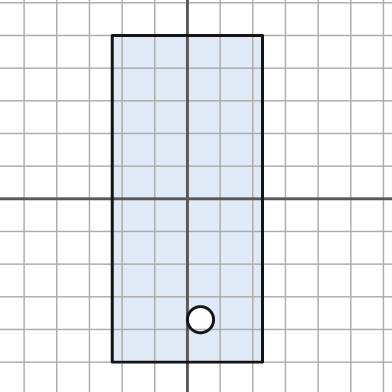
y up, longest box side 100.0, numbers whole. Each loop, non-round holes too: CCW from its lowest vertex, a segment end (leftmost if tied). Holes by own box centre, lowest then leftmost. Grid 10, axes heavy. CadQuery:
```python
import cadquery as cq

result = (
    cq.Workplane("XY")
    .moveTo(-23.0, -50.0)
    .lineTo(23.0, -50.0)
    .lineTo(23.0, 50.0)
    .lineTo(-23.0, 50.0)
    .close()
    .moveTo(4.0, -37.0)
    .circle(4.0)
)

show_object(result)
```